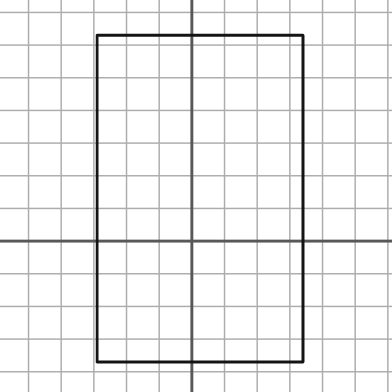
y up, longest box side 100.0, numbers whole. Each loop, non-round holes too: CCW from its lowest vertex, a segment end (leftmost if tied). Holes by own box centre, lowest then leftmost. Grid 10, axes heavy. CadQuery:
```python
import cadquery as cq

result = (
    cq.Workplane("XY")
    .moveTo(-29.0, -37.0)
    .lineTo(34.0, -37.0)
    .lineTo(34.0, 63.0)
    .lineTo(-29.0, 63.0)
    .close()
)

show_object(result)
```